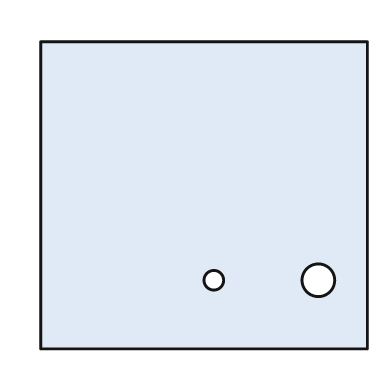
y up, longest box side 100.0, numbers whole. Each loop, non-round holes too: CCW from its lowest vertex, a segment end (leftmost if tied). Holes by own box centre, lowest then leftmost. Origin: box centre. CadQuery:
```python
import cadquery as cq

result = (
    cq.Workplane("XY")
    .moveTo(-50.0, -47.0)
    .lineTo(50.0, -47.0)
    .lineTo(50.0, 47.0)
    .lineTo(-50.0, 47.0)
    .close()
    .moveTo(3.0, -26.0)
    .circle(3.0)
    .moveTo(35.0, -26.0)
    .circle(5.0)
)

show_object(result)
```